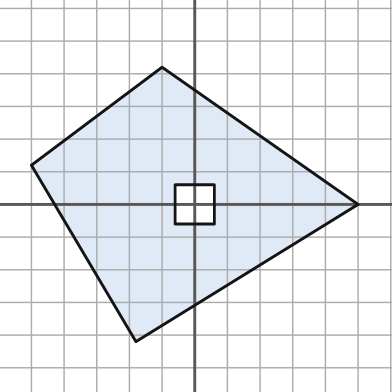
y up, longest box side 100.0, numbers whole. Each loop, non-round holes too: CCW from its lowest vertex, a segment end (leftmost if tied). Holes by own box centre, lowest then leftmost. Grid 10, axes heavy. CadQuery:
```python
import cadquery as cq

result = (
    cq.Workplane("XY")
    .moveTo(-18.0, -42.0)
    .lineTo(50.0, 0.0)
    .lineTo(-10.0, 42.0)
    .lineTo(-50.0, 12.0)
    .close()
    .moveTo(-6.0, -6.0)
    .lineTo(6.0, -6.0)
    .lineTo(6.0, 6.0)
    .lineTo(-6.0, 6.0)
    .close()
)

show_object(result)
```